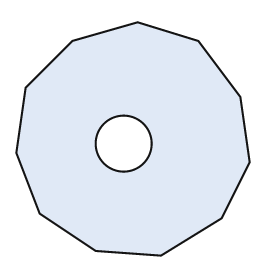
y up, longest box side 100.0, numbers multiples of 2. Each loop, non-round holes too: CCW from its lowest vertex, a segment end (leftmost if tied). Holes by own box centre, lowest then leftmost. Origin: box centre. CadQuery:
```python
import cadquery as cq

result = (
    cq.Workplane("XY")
    .moveTo(12.0, -50.0)
    .lineTo(38.0, -34.0)
    .lineTo(50.0, -10.0)
    .lineTo(46.0, 18.0)
    .lineTo(28.0, 42.0)
    .lineTo(2.0, 50.0)
    .lineTo(-26.0, 42.0)
    .lineTo(-46.0, 22.0)
    .lineTo(-50.0, -6.0)
    .lineTo(-40.0, -32.0)
    .lineTo(-16.0, -48.0)
    .close()
    .moveTo(-4.0, -2.0)
    .circle(12.0)
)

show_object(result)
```